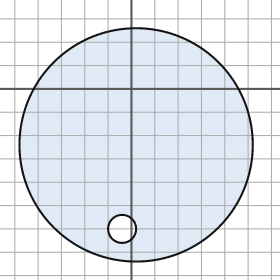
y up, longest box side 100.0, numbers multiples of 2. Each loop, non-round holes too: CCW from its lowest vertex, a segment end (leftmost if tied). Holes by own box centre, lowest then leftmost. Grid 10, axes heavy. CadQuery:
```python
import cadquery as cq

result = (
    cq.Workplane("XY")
    .moveTo(2.0, -24.0)
    .circle(50.0)
    .moveTo(-4.0, -60.0)
    .circle(6.0)
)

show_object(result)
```